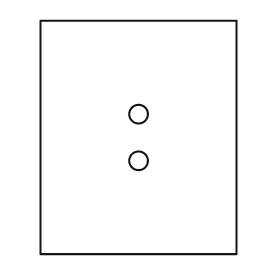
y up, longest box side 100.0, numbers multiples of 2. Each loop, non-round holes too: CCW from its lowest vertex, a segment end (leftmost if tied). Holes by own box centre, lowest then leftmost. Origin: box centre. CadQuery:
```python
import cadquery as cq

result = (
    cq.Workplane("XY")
    .moveTo(-42.0, -50.0)
    .lineTo(42.0, -50.0)
    .lineTo(42.0, 50.0)
    .lineTo(-42.0, 50.0)
    .close()
    .moveTo(0.0, -10.0)
    .circle(4.0)
    .moveTo(0.0, 10.0)
    .circle(4.0)
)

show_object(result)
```